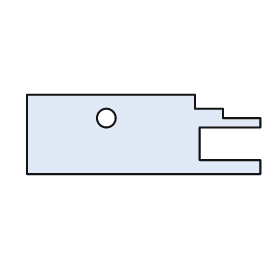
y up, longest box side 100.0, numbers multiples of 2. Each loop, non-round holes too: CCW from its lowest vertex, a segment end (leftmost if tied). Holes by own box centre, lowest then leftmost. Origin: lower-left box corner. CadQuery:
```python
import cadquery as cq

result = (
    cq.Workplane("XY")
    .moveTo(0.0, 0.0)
    .lineTo(100.0, 0.0)
    .lineTo(100.0, 6.0)
    .lineTo(74.0, 6.0)
    .lineTo(74.0, 20.0)
    .lineTo(100.0, 20.0)
    .lineTo(100.0, 24.0)
    .lineTo(84.0, 24.0)
    .lineTo(84.0, 28.0)
    .lineTo(72.0, 28.0)
    .lineTo(72.0, 34.0)
    .lineTo(0.0, 34.0)
    .close()
    .moveTo(34.0, 24.0)
    .circle(4.0)
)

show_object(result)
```